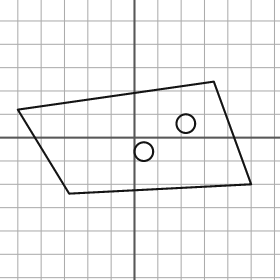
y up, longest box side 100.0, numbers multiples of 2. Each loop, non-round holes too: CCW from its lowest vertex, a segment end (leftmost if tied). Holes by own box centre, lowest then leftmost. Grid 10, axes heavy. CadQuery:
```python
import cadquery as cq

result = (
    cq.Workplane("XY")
    .moveTo(-28.0, -24.0)
    .lineTo(50.0, -20.0)
    .lineTo(34.0, 24.0)
    .lineTo(-50.0, 12.0)
    .close()
    .moveTo(4.0, -6.0)
    .circle(4.0)
    .moveTo(22.0, 6.0)
    .circle(4.0)
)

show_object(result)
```